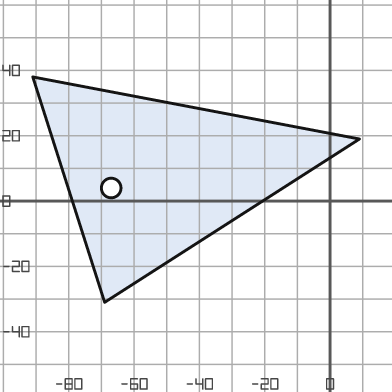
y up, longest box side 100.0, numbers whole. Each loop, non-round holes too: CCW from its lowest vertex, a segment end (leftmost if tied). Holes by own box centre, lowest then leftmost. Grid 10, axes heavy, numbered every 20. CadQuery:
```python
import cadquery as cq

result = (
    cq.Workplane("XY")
    .moveTo(-69.0, -31.0)
    .lineTo(9.0, 19.0)
    .lineTo(-91.0, 38.0)
    .close()
    .moveTo(-67.0, 4.0)
    .circle(3.0)
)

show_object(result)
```